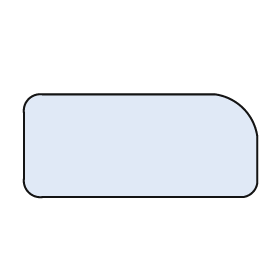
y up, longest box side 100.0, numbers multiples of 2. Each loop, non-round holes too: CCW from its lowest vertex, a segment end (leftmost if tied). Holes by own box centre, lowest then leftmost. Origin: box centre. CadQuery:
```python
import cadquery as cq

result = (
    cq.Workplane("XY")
    .moveTo(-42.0, -22.0)
    .lineTo(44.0, -22.0)
    .threePointArc((48.0, -20.0), (50.0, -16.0))
    .lineTo(50.0, 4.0)
    .threePointArc((44.0, 16.0), (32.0, 22.0))
    .lineTo(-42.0, 22.0)
    .threePointArc((-48.0, 20.0), (-50.0, 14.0))
    .lineTo(-50.0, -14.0)
    .threePointArc((-48.0, -20.0), (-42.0, -22.0))
    .close()
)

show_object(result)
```